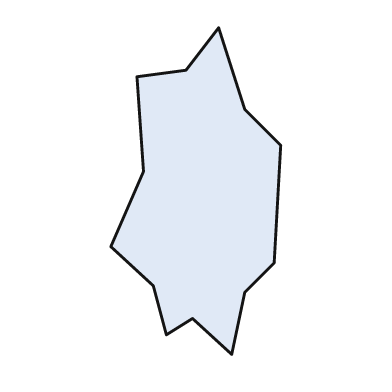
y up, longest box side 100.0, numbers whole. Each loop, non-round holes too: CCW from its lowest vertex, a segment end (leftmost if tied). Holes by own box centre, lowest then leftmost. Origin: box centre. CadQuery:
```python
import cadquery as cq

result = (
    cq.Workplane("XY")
    .moveTo(11.0, -50.0)
    .lineTo(15.0, -31.0)
    .lineTo(24.0, -22.0)
    .lineTo(26.0, 14.0)
    .lineTo(15.0, 25.0)
    .lineTo(7.0, 50.0)
    .lineTo(-3.0, 37.0)
    .lineTo(-18.0, 35.0)
    .lineTo(-16.0, 6.0)
    .lineTo(-26.0, -17.0)
    .lineTo(-13.0, -29.0)
    .lineTo(-9.0, -44.0)
    .lineTo(-1.0, -39.0)
    .close()
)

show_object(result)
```